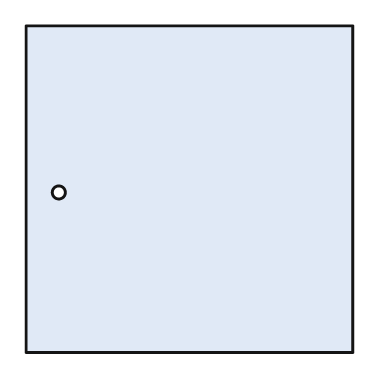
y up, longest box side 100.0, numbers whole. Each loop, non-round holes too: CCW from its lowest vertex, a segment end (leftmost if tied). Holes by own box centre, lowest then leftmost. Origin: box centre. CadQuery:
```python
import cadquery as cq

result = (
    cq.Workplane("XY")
    .moveTo(-50.0, -50.0)
    .lineTo(50.0, -50.0)
    .lineTo(50.0, 50.0)
    .lineTo(-50.0, 50.0)
    .close()
    .moveTo(-40.0, -1.0)
    .circle(2.0)
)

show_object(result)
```